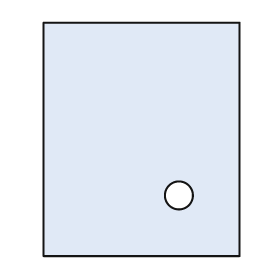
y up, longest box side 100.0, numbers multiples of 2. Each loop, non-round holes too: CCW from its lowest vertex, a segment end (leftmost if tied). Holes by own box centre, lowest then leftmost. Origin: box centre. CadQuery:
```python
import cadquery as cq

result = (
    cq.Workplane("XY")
    .moveTo(-42.0, -50.0)
    .lineTo(42.0, -50.0)
    .lineTo(42.0, 50.0)
    .lineTo(-42.0, 50.0)
    .close()
    .moveTo(16.0, -24.0)
    .circle(6.0)
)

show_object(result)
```